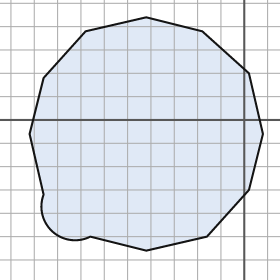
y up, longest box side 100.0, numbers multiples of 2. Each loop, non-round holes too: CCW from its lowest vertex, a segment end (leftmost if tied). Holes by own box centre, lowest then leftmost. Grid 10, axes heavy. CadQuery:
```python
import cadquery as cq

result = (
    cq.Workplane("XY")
    .moveTo(-42.0, -56.0)
    .lineTo(-16.0, -50.0)
    .lineTo(2.0, -30.0)
    .lineTo(8.0, -6.0)
    .lineTo(2.0, 20.0)
    .lineTo(-18.0, 38.0)
    .lineTo(-42.0, 44.0)
    .lineTo(-68.0, 38.0)
    .lineTo(-86.0, 18.0)
    .lineTo(-92.0, -6.0)
    .lineTo(-86.0, -32.0)
    .threePointArc((-82.0, -48.0), (-66.0, -50.0))
    .close()
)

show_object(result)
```